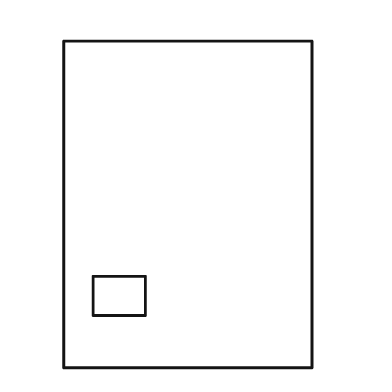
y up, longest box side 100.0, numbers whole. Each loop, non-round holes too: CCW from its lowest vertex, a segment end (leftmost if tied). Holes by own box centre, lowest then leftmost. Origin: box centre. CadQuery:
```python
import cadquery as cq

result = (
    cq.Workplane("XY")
    .moveTo(-38.0, -50.0)
    .lineTo(38.0, -50.0)
    .lineTo(38.0, 50.0)
    .lineTo(-38.0, 50.0)
    .close()
    .moveTo(-29.0, -34.0)
    .lineTo(-13.0, -34.0)
    .lineTo(-13.0, -22.0)
    .lineTo(-29.0, -22.0)
    .close()
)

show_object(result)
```